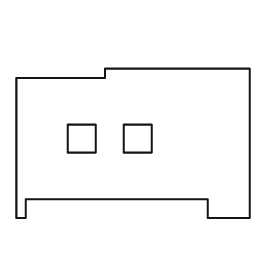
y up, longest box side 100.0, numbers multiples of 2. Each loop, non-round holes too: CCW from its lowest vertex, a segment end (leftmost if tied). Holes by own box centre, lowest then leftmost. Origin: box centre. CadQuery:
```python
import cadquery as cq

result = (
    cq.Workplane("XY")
    .moveTo(-50.0, -32.0)
    .lineTo(-46.0, -32.0)
    .lineTo(-46.0, -24.0)
    .lineTo(32.0, -24.0)
    .lineTo(32.0, -32.0)
    .lineTo(50.0, -32.0)
    .lineTo(50.0, 32.0)
    .lineTo(-12.0, 32.0)
    .lineTo(-12.0, 28.0)
    .lineTo(-50.0, 28.0)
    .close()
    .moveTo(-28.0, -4.0)
    .lineTo(-16.0, -4.0)
    .lineTo(-16.0, 8.0)
    .lineTo(-28.0, 8.0)
    .close()
    .moveTo(-4.0, -4.0)
    .lineTo(8.0, -4.0)
    .lineTo(8.0, 8.0)
    .lineTo(-4.0, 8.0)
    .close()
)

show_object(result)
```